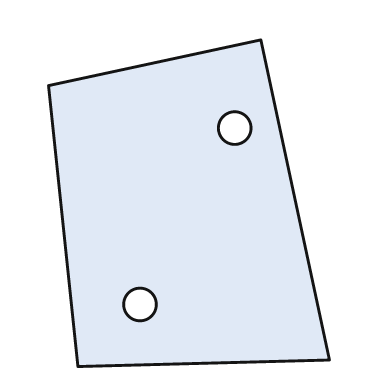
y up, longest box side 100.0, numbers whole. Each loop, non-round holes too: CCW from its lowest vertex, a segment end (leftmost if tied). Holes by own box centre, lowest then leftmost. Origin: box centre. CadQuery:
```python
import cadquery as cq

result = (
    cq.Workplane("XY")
    .moveTo(-34.0, -50.0)
    .lineTo(43.0, -48.0)
    .lineTo(22.0, 50.0)
    .lineTo(-43.0, 36.0)
    .close()
    .moveTo(-15.0, -31.0)
    .circle(5.0)
    .moveTo(14.0, 23.0)
    .circle(5.0)
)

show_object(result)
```